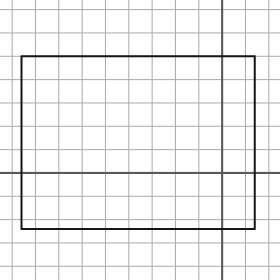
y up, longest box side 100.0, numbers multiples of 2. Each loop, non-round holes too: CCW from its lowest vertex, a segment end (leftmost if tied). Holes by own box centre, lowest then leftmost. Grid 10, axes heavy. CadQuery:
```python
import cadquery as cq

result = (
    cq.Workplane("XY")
    .moveTo(-86.0, -24.0)
    .lineTo(14.0, -24.0)
    .lineTo(14.0, 50.0)
    .lineTo(-86.0, 50.0)
    .close()
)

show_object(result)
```